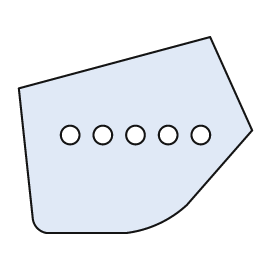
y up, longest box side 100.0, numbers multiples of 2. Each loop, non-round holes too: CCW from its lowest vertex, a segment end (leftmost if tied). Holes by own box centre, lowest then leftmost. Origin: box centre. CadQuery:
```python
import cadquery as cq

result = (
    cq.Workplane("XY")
    .moveTo(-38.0, -42.0)
    .lineTo(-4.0, -42.0)
    .threePointArc((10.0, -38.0), (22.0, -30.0))
    .lineTo(50.0, 2.0)
    .lineTo(32.0, 42.0)
    .lineTo(-50.0, 20.0)
    .lineTo(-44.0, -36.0)
    .threePointArc((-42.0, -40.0), (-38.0, -42.0))
    .close()
    .moveTo(-28.0, 0.0)
    .circle(4.0)
    .moveTo(-14.0, 0.0)
    .circle(4.0)
    .moveTo(0.0, 0.0)
    .circle(4.0)
    .moveTo(14.0, 0.0)
    .circle(4.0)
    .moveTo(28.0, 0.0)
    .circle(4.0)
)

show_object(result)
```